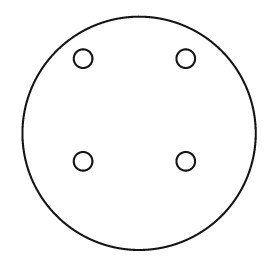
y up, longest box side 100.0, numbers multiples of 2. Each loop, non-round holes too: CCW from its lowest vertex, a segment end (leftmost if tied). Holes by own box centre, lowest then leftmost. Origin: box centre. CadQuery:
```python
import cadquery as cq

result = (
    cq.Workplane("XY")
    .moveTo(0.0, 0.0)
    .circle(50.0)
    .moveTo(-24.0, -12.0)
    .circle(4.0)
    .moveTo(20.0, -12.0)
    .circle(4.0)
    .moveTo(-24.0, 32.0)
    .circle(4.0)
    .moveTo(20.0, 32.0)
    .circle(4.0)
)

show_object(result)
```